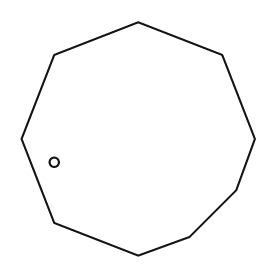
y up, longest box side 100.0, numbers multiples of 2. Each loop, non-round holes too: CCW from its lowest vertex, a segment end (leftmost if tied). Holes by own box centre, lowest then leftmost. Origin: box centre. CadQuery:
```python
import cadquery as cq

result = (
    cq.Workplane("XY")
    .moveTo(0.0, -50.0)
    .lineTo(22.0, -42.0)
    .lineTo(42.0, -22.0)
    .lineTo(50.0, 0.0)
    .lineTo(36.0, 36.0)
    .lineTo(0.0, 50.0)
    .lineTo(-36.0, 36.0)
    .lineTo(-50.0, 0.0)
    .lineTo(-36.0, -36.0)
    .close()
    .moveTo(-36.0, -10.0)
    .circle(2.0)
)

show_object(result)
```